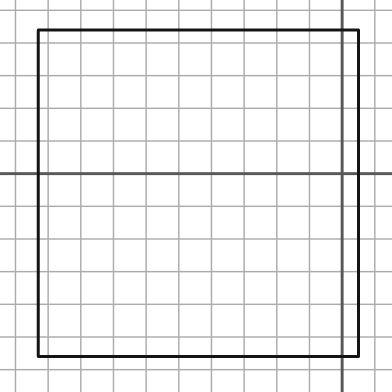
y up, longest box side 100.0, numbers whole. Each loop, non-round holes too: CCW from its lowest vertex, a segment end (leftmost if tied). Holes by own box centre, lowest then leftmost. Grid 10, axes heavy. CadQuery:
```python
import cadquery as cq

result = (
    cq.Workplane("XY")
    .moveTo(-93.0, -56.0)
    .lineTo(5.0, -56.0)
    .lineTo(5.0, 44.0)
    .lineTo(-93.0, 44.0)
    .close()
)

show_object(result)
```